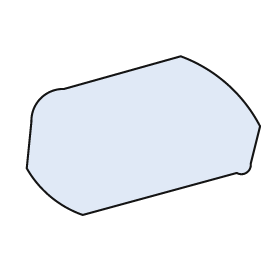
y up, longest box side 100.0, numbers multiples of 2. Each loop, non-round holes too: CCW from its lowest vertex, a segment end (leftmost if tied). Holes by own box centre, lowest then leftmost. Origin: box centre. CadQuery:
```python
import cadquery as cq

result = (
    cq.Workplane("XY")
    .moveTo(-26.0, -34.0)
    .lineTo(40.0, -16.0)
    .threePointArc((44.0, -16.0), (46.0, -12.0))
    .lineTo(50.0, 4.0)
    .threePointArc((36.0, 22.0), (16.0, 34.0))
    .lineTo(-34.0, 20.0)
    .threePointArc((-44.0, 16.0), (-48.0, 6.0))
    .lineTo(-50.0, -14.0)
    .threePointArc((-40.0, -26.0), (-26.0, -34.0))
    .close()
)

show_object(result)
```